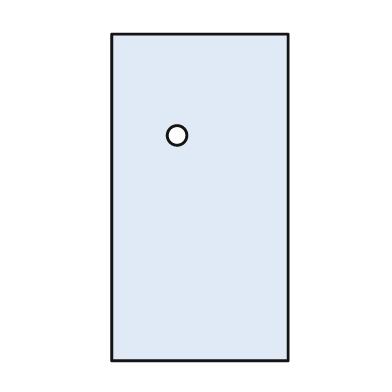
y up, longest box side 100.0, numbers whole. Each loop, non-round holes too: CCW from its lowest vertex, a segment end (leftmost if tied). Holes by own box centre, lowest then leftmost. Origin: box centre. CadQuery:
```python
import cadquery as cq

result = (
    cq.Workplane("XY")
    .moveTo(-27.0, -50.0)
    .lineTo(27.0, -50.0)
    .lineTo(27.0, 50.0)
    .lineTo(-27.0, 50.0)
    .close()
    .moveTo(-7.0, 19.0)
    .circle(3.0)
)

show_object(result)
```